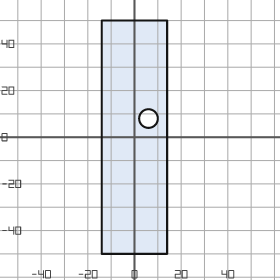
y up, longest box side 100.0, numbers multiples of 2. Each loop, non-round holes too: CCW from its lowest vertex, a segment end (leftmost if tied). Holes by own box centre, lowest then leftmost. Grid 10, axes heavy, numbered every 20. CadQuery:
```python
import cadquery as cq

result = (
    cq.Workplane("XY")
    .moveTo(-14.0, -50.0)
    .lineTo(14.0, -50.0)
    .lineTo(14.0, 50.0)
    .lineTo(-14.0, 50.0)
    .close()
    .moveTo(6.0, 8.0)
    .circle(4.0)
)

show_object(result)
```